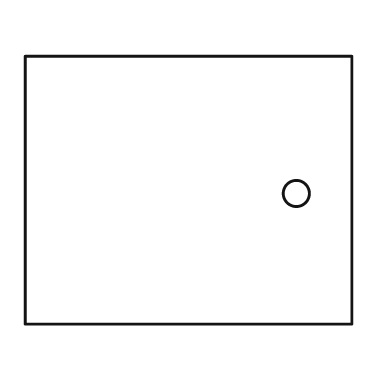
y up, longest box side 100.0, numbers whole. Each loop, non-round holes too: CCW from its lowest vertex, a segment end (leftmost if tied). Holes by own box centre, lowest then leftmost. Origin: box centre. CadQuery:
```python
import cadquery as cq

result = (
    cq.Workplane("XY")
    .moveTo(-50.0, -41.0)
    .lineTo(50.0, -41.0)
    .lineTo(50.0, 41.0)
    .lineTo(-50.0, 41.0)
    .close()
    .moveTo(33.0, -1.0)
    .circle(4.0)
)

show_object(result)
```